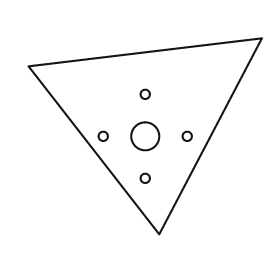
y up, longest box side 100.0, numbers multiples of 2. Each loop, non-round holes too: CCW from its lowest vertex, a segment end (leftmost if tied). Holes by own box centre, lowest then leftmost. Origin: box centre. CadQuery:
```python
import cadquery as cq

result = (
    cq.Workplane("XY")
    .moveTo(6.0, -42.0)
    .lineTo(50.0, 42.0)
    .lineTo(-50.0, 30.0)
    .close()
    .moveTo(0.0, -18.0)
    .circle(2.0)
    .moveTo(-18.0, 0.0)
    .circle(2.0)
    .moveTo(0.0, 0.0)
    .circle(6.0)
    .moveTo(18.0, 0.0)
    .circle(2.0)
    .moveTo(0.0, 18.0)
    .circle(2.0)
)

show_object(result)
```